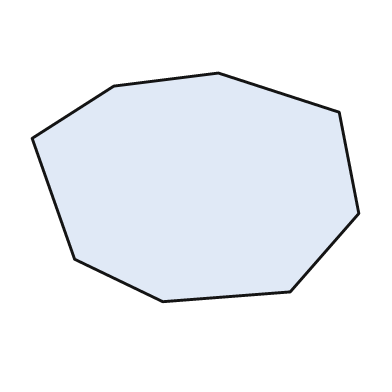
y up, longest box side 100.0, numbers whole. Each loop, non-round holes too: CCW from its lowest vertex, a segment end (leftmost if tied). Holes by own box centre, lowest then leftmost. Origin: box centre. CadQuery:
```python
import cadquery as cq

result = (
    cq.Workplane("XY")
    .moveTo(-10.0, -35.0)
    .lineTo(29.0, -32.0)
    .lineTo(50.0, -8.0)
    .lineTo(44.0, 23.0)
    .lineTo(7.0, 35.0)
    .lineTo(-25.0, 31.0)
    .lineTo(-50.0, 15.0)
    .lineTo(-37.0, -22.0)
    .close()
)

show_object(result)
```